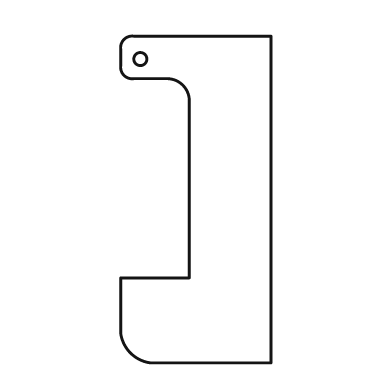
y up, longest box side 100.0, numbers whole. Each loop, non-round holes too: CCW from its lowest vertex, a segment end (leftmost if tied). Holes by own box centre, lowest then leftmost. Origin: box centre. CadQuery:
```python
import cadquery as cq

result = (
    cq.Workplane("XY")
    .moveTo(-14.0, -50.0)
    .lineTo(23.0, -50.0)
    .lineTo(23.0, 50.0)
    .lineTo(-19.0, 50.0)
    .threePointArc((-22.0, 49.0), (-23.0, 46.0))
    .lineTo(-23.0, 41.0)
    .threePointArc((-22.0, 38.0), (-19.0, 37.0))
    .lineTo(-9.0, 37.0)
    .threePointArc((-4.0, 35.0), (-2.0, 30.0))
    .lineTo(-2.0, -24.0)
    .lineTo(-23.0, -24.0)
    .lineTo(-23.0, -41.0)
    .threePointArc((-20.0, -47.0), (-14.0, -50.0))
    .close()
    .moveTo(-17.0, 43.0)
    .circle(2.0)
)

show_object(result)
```